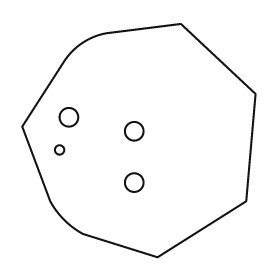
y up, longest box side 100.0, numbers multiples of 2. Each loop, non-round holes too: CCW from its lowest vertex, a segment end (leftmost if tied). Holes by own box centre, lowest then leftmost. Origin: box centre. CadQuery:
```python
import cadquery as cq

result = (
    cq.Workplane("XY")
    .moveTo(8.0, -50.0)
    .lineTo(46.0, -26.0)
    .lineTo(50.0, 20.0)
    .lineTo(18.0, 50.0)
    .lineTo(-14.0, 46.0)
    .threePointArc((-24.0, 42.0), (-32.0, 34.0))
    .lineTo(-50.0, 6.0)
    .lineTo(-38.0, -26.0)
    .threePointArc((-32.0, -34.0), (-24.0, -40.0))
    .close()
    .moveTo(-2.0, -18.0)
    .circle(4.0)
    .moveTo(-34.0, -4.0)
    .circle(2.0)
    .moveTo(-2.0, 4.0)
    .circle(4.0)
    .moveTo(-30.0, 10.0)
    .circle(4.0)
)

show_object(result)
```